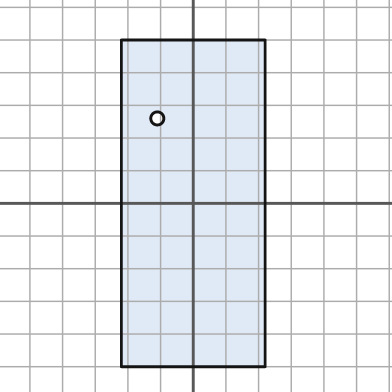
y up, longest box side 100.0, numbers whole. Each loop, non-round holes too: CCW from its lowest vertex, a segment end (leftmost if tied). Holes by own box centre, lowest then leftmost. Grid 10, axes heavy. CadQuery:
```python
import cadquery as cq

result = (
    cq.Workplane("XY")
    .moveTo(-22.0, -50.0)
    .lineTo(22.0, -50.0)
    .lineTo(22.0, 50.0)
    .lineTo(-22.0, 50.0)
    .close()
    .moveTo(-11.0, 26.0)
    .circle(2.0)
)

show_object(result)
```